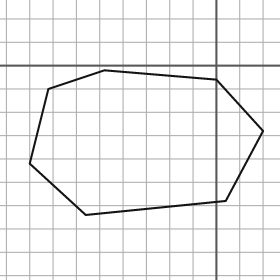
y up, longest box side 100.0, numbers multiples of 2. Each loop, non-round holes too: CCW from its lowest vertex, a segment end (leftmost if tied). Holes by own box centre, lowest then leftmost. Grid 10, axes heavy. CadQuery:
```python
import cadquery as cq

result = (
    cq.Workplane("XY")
    .moveTo(-56.0, -64.0)
    .lineTo(4.0, -58.0)
    .lineTo(20.0, -28.0)
    .lineTo(0.0, -6.0)
    .lineTo(-48.0, -2.0)
    .lineTo(-72.0, -10.0)
    .lineTo(-80.0, -42.0)
    .close()
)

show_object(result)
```